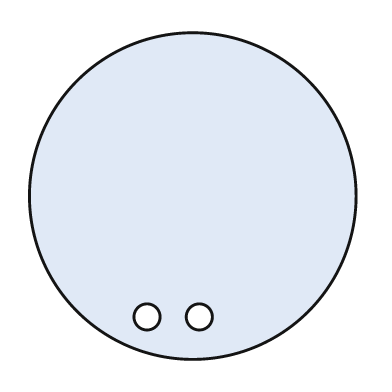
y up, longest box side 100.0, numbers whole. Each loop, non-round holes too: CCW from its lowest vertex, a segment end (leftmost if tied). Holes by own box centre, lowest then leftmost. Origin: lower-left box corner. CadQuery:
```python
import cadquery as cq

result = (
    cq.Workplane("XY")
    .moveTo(50.0, 50.0)
    .circle(50.0)
    .moveTo(36.0, 13.0)
    .circle(4.0)
    .moveTo(52.0, 13.0)
    .circle(4.0)
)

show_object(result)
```